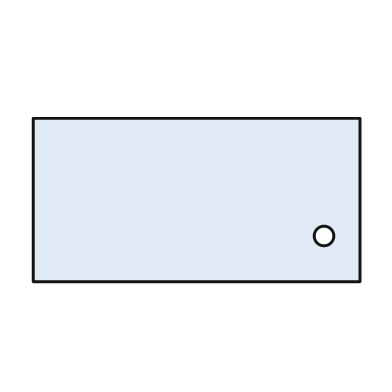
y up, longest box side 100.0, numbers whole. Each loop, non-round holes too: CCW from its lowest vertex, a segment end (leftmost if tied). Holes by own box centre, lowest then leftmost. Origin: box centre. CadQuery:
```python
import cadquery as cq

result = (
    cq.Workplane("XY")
    .moveTo(-50.0, -25.0)
    .lineTo(50.0, -25.0)
    .lineTo(50.0, 25.0)
    .lineTo(-50.0, 25.0)
    .close()
    .moveTo(39.0, -11.0)
    .circle(3.0)
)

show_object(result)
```